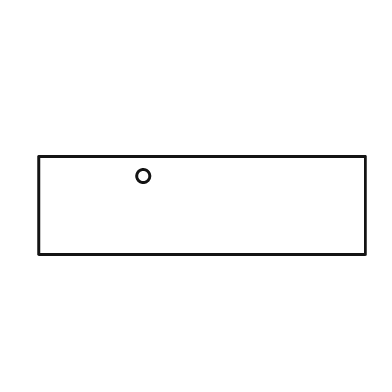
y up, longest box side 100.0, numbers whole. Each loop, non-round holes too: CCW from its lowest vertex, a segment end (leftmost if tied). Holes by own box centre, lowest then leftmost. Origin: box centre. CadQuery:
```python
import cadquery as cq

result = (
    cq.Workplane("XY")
    .moveTo(-50.0, -15.0)
    .lineTo(50.0, -15.0)
    .lineTo(50.0, 15.0)
    .lineTo(-50.0, 15.0)
    .close()
    .moveTo(-18.0, 9.0)
    .circle(2.0)
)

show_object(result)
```